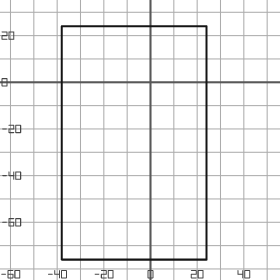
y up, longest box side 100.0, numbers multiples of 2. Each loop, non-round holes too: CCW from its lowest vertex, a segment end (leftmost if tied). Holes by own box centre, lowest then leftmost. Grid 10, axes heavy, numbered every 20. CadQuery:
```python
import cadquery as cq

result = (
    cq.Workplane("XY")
    .moveTo(-38.0, -76.0)
    .lineTo(24.0, -76.0)
    .lineTo(24.0, 24.0)
    .lineTo(-38.0, 24.0)
    .close()
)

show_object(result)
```